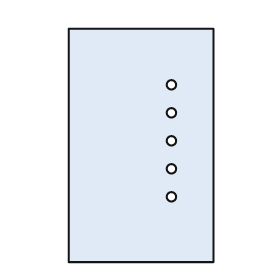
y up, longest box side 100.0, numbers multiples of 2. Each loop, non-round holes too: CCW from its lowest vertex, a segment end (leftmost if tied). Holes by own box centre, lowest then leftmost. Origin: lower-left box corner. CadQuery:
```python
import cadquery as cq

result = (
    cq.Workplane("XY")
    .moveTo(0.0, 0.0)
    .lineTo(62.0, 0.0)
    .lineTo(62.0, 100.0)
    .lineTo(0.0, 100.0)
    .close()
    .moveTo(44.0, 28.0)
    .circle(2.0)
    .moveTo(44.0, 40.0)
    .circle(2.0)
    .moveTo(44.0, 52.0)
    .circle(2.0)
    .moveTo(44.0, 64.0)
    .circle(2.0)
    .moveTo(44.0, 76.0)
    .circle(2.0)
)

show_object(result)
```